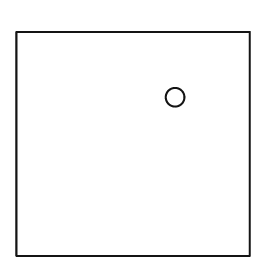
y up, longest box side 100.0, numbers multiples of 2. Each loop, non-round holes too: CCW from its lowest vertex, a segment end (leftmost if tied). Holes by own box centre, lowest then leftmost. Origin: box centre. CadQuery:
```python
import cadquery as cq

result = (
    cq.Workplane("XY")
    .moveTo(-50.0, -48.0)
    .lineTo(50.0, -48.0)
    .lineTo(50.0, 48.0)
    .lineTo(-50.0, 48.0)
    .close()
    .moveTo(18.0, 20.0)
    .circle(4.0)
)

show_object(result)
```